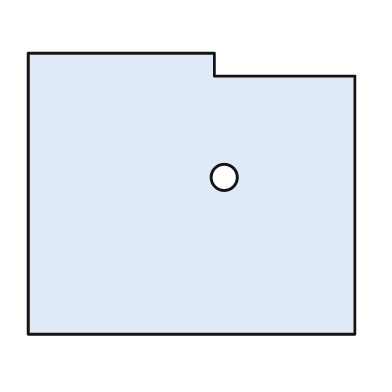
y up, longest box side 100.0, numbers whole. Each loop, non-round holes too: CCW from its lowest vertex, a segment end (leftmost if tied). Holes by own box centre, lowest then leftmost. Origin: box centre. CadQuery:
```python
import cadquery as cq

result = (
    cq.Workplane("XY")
    .moveTo(-50.0, -43.0)
    .lineTo(50.0, -43.0)
    .lineTo(50.0, 36.0)
    .lineTo(7.0, 36.0)
    .lineTo(7.0, 43.0)
    .lineTo(-50.0, 43.0)
    .close()
    .moveTo(10.0, 5.0)
    .circle(4.0)
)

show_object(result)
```